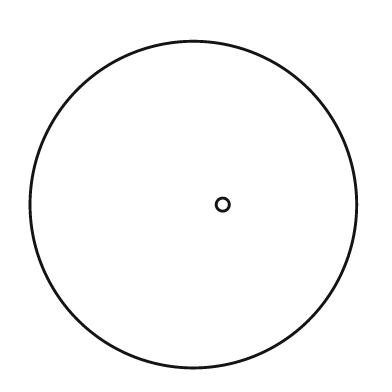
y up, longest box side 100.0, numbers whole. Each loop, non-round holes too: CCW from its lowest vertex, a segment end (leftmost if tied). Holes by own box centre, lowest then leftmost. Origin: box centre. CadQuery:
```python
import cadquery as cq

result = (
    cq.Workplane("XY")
    .moveTo(0.0, 0.0)
    .circle(50.0)
    .moveTo(9.0, 0.0)
    .circle(2.0)
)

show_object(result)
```